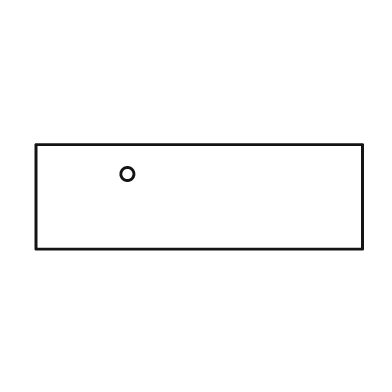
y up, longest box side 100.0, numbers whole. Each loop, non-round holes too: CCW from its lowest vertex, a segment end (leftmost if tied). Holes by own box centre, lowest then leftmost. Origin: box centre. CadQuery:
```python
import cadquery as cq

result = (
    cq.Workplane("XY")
    .moveTo(-50.0, -16.0)
    .lineTo(50.0, -16.0)
    .lineTo(50.0, 16.0)
    .lineTo(-50.0, 16.0)
    .close()
    .moveTo(-22.0, 7.0)
    .circle(2.0)
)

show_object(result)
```